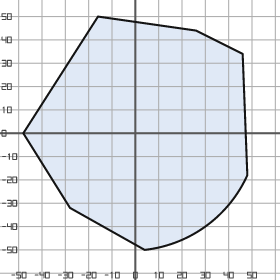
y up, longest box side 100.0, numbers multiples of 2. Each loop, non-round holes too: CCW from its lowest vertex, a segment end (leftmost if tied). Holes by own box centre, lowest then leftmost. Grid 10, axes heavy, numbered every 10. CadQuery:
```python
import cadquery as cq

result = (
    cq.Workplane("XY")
    .moveTo(4.0, -50.0)
    .threePointArc((30.0, -40.0), (48.0, -18.0))
    .lineTo(46.0, 34.0)
    .lineTo(26.0, 44.0)
    .lineTo(-16.0, 50.0)
    .lineTo(-48.0, 0.0)
    .lineTo(-28.0, -32.0)
    .close()
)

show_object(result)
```